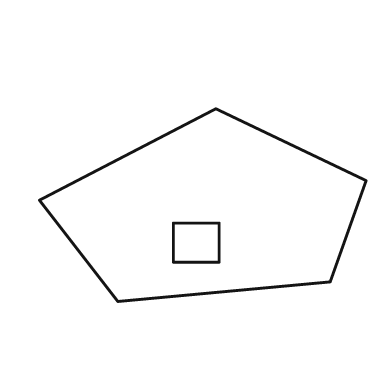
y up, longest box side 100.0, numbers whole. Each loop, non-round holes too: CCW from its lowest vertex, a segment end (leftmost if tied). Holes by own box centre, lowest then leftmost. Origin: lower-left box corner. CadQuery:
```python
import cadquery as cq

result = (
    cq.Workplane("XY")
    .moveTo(24.0, 0.0)
    .lineTo(89.0, 6.0)
    .lineTo(100.0, 37.0)
    .lineTo(54.0, 59.0)
    .lineTo(0.0, 31.0)
    .close()
    .moveTo(41.0, 12.0)
    .lineTo(55.0, 12.0)
    .lineTo(55.0, 24.0)
    .lineTo(41.0, 24.0)
    .close()
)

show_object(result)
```